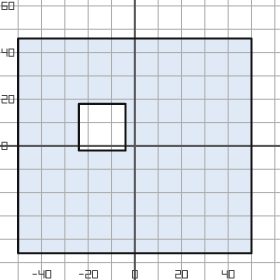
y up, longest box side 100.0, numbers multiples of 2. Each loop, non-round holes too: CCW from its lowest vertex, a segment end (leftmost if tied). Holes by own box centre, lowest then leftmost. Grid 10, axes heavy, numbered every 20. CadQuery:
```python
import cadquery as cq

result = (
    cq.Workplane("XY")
    .moveTo(-50.0, -46.0)
    .lineTo(50.0, -46.0)
    .lineTo(50.0, 46.0)
    .lineTo(-50.0, 46.0)
    .close()
    .moveTo(-24.0, -2.0)
    .lineTo(-4.0, -2.0)
    .lineTo(-4.0, 18.0)
    .lineTo(-24.0, 18.0)
    .close()
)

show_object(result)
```